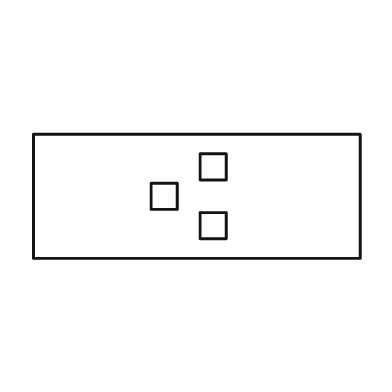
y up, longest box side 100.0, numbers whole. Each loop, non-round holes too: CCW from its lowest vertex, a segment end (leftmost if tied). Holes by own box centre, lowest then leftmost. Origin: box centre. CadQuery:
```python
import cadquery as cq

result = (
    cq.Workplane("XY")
    .moveTo(-50.0, -19.0)
    .lineTo(50.0, -19.0)
    .lineTo(50.0, 19.0)
    .lineTo(-50.0, 19.0)
    .close()
    .moveTo(1.0, -13.0)
    .lineTo(9.0, -13.0)
    .lineTo(9.0, -5.0)
    .lineTo(1.0, -5.0)
    .close()
    .moveTo(-14.0, -4.0)
    .lineTo(-6.0, -4.0)
    .lineTo(-6.0, 4.0)
    .lineTo(-14.0, 4.0)
    .close()
    .moveTo(1.0, 5.0)
    .lineTo(9.0, 5.0)
    .lineTo(9.0, 13.0)
    .lineTo(1.0, 13.0)
    .close()
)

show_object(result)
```